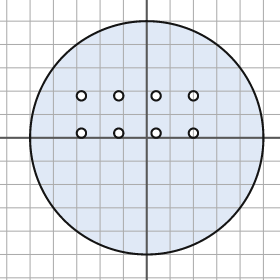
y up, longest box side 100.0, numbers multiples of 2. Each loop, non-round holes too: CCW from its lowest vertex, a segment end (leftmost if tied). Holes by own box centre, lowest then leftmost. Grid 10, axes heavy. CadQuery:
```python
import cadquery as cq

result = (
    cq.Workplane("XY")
    .moveTo(0.0, 0.0)
    .circle(50.0)
    .moveTo(-28.0, 2.0)
    .circle(2.0)
    .moveTo(-12.0, 2.0)
    .circle(2.0)
    .moveTo(4.0, 2.0)
    .circle(2.0)
    .moveTo(20.0, 2.0)
    .circle(2.0)
    .moveTo(-28.0, 18.0)
    .circle(2.0)
    .moveTo(-12.0, 18.0)
    .circle(2.0)
    .moveTo(4.0, 18.0)
    .circle(2.0)
    .moveTo(20.0, 18.0)
    .circle(2.0)
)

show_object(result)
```